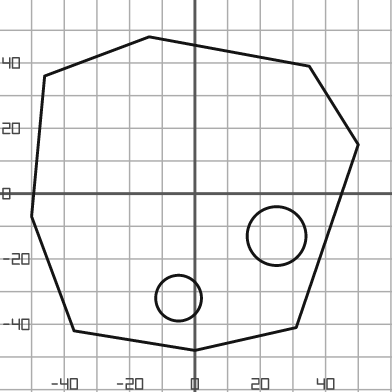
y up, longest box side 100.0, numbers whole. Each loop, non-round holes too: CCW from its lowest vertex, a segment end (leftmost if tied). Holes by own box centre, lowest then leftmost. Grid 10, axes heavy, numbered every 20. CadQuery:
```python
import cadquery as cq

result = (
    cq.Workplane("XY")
    .moveTo(0.0, -48.0)
    .lineTo(31.0, -41.0)
    .lineTo(50.0, 15.0)
    .lineTo(35.0, 39.0)
    .lineTo(-14.0, 48.0)
    .lineTo(-46.0, 36.0)
    .lineTo(-50.0, -7.0)
    .lineTo(-37.0, -42.0)
    .close()
    .moveTo(-5.0, -32.0)
    .circle(7.0)
    .moveTo(25.0, -13.0)
    .circle(9.0)
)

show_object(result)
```